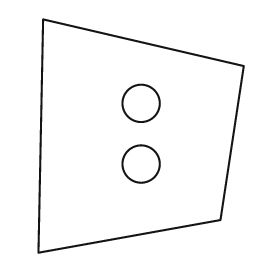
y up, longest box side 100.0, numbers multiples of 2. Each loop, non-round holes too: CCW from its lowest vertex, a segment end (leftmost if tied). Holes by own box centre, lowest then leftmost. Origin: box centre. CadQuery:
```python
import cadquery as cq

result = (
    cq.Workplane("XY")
    .moveTo(-44.0, -50.0)
    .lineTo(34.0, -36.0)
    .lineTo(44.0, 30.0)
    .lineTo(-42.0, 50.0)
    .close()
    .moveTo(0.0, -12.0)
    .circle(8.0)
    .moveTo(0.0, 14.0)
    .circle(8.0)
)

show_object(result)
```